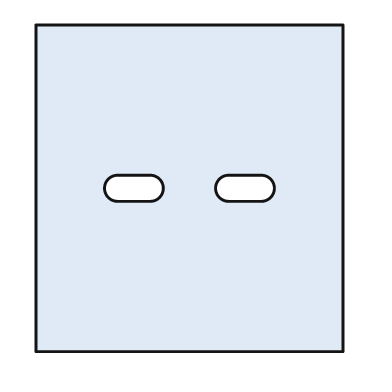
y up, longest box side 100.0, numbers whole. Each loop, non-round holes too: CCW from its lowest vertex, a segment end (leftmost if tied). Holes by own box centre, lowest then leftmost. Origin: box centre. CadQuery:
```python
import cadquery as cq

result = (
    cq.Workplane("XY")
    .moveTo(-47.0, -50.0)
    .lineTo(47.0, -50.0)
    .lineTo(47.0, 50.0)
    .lineTo(-47.0, 50.0)
    .close()
    .moveTo(-22.0, -4.0)
    .lineTo(-12.0, -4.0)
    .threePointArc((-8.0, 0.0), (-12.0, 4.0))
    .lineTo(-22.0, 4.0)
    .threePointArc((-26.0, 0.0), (-22.0, -4.0))
    .close()
    .moveTo(12.0, -4.0)
    .lineTo(22.0, -4.0)
    .threePointArc((26.0, 0.0), (22.0, 4.0))
    .lineTo(12.0, 4.0)
    .threePointArc((8.0, 0.0), (12.0, -4.0))
    .close()
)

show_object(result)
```